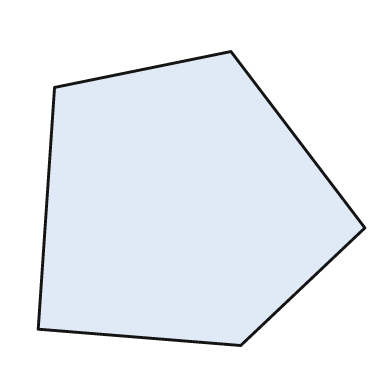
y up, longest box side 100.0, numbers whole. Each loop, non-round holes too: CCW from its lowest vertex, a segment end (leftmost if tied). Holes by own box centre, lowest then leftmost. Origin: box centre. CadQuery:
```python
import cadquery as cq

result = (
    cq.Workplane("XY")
    .moveTo(12.0, -45.0)
    .lineTo(50.0, -9.0)
    .lineTo(9.0, 45.0)
    .lineTo(-45.0, 34.0)
    .lineTo(-50.0, -40.0)
    .close()
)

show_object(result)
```